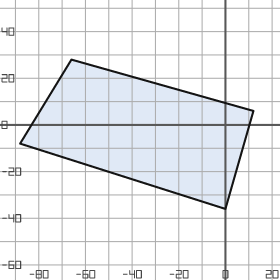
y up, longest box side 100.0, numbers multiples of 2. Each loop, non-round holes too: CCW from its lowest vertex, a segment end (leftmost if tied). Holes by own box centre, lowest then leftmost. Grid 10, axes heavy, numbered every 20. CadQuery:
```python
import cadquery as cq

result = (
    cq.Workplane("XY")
    .moveTo(0.0, -36.0)
    .lineTo(12.0, 6.0)
    .lineTo(-66.0, 28.0)
    .lineTo(-88.0, -8.0)
    .close()
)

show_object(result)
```